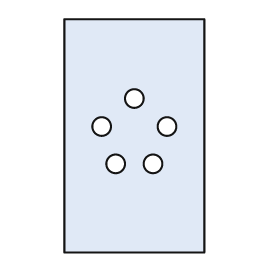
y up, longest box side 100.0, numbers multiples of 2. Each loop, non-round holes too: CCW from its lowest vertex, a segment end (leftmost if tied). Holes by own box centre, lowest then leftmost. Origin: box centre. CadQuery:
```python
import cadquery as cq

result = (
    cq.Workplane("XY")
    .moveTo(-30.0, -50.0)
    .lineTo(30.0, -50.0)
    .lineTo(30.0, 50.0)
    .lineTo(-30.0, 50.0)
    .close()
    .moveTo(-8.0, -12.0)
    .circle(4.0)
    .moveTo(8.0, -12.0)
    .circle(4.0)
    .moveTo(-14.0, 4.0)
    .circle(4.0)
    .moveTo(14.0, 4.0)
    .circle(4.0)
    .moveTo(0.0, 16.0)
    .circle(4.0)
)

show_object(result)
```